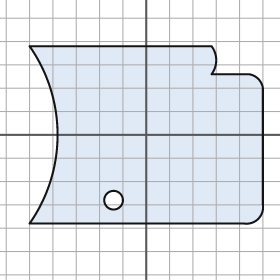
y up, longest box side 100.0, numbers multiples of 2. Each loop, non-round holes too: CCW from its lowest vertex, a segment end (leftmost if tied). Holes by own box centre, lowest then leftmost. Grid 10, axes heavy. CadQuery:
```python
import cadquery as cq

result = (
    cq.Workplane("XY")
    .moveTo(-50.0, -38.0)
    .lineTo(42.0, -38.0)
    .threePointArc((48.0, -36.0), (50.0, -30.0))
    .lineTo(50.0, 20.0)
    .threePointArc((48.0, 24.0), (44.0, 26.0))
    .lineTo(28.0, 26.0)
    .threePointArc((30.0, 32.0), (28.0, 38.0))
    .lineTo(-50.0, 38.0)
    .threePointArc((-38.0, 0.0), (-50.0, -38.0))
    .close()
    .moveTo(-14.0, -28.0)
    .circle(4.0)
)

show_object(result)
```